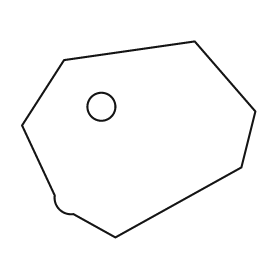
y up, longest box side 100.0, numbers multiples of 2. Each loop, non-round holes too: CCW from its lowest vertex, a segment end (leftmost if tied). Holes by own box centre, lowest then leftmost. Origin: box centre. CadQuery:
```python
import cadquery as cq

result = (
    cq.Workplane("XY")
    .moveTo(-10.0, -42.0)
    .lineTo(44.0, -12.0)
    .lineTo(50.0, 12.0)
    .lineTo(24.0, 42.0)
    .lineTo(-32.0, 34.0)
    .lineTo(-50.0, 6.0)
    .lineTo(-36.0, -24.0)
    .threePointArc((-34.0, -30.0), (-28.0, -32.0))
    .close()
    .moveTo(-16.0, 14.0)
    .circle(6.0)
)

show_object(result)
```